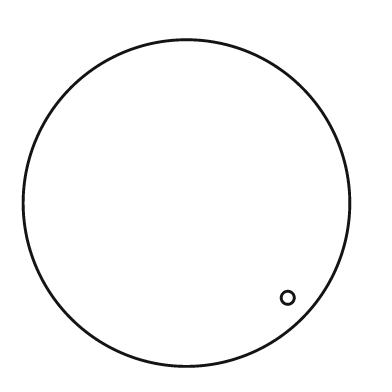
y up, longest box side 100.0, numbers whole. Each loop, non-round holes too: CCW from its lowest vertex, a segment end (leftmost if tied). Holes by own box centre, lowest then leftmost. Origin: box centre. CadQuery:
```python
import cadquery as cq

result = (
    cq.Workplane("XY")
    .moveTo(0.0, 0.0)
    .circle(50.0)
    .moveTo(31.0, -29.0)
    .circle(2.0)
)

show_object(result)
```